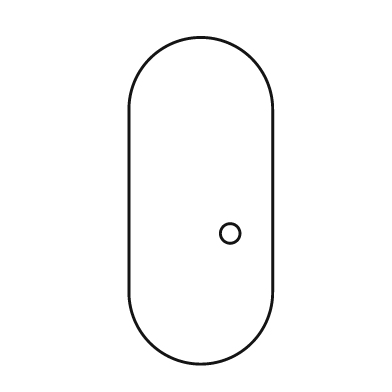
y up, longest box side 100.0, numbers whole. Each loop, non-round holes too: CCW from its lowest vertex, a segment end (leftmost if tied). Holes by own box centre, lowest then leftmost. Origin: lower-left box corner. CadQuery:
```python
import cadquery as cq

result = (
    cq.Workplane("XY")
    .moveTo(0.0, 22.0)
    .threePointArc((22.0, 0.0), (44.0, 22.0))
    .lineTo(44.0, 78.0)
    .threePointArc((22.0, 100.0), (0.0, 78.0))
    .close()
    .moveTo(31.0, 40.0)
    .circle(3.0)
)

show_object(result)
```